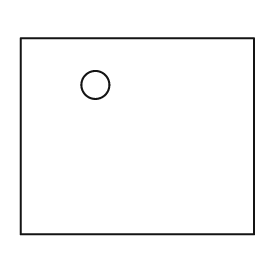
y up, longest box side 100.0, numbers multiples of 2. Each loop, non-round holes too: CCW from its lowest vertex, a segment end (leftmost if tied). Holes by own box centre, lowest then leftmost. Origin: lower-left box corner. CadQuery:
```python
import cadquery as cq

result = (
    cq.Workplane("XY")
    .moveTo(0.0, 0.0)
    .lineTo(100.0, 0.0)
    .lineTo(100.0, 84.0)
    .lineTo(0.0, 84.0)
    .close()
    .moveTo(32.0, 64.0)
    .circle(6.0)
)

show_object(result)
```